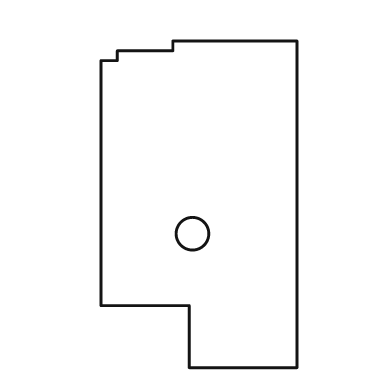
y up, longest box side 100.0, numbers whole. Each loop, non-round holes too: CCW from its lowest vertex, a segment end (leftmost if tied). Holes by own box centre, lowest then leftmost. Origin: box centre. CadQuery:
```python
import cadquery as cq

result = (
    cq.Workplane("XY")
    .moveTo(-3.0, -50.0)
    .lineTo(30.0, -50.0)
    .lineTo(30.0, 50.0)
    .lineTo(-8.0, 50.0)
    .lineTo(-8.0, 47.0)
    .lineTo(-25.0, 47.0)
    .lineTo(-25.0, 44.0)
    .lineTo(-30.0, 44.0)
    .lineTo(-30.0, -31.0)
    .lineTo(-3.0, -31.0)
    .close()
    .moveTo(-2.0, -9.0)
    .circle(5.0)
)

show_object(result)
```